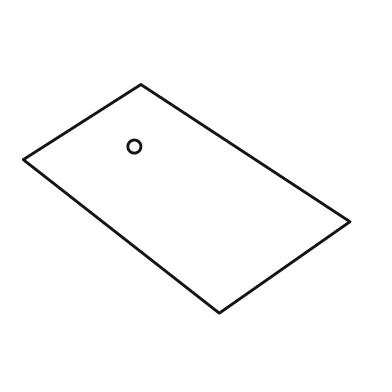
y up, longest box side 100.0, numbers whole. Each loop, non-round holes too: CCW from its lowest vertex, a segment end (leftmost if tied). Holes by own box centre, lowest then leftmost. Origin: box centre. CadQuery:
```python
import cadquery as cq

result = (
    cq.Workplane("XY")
    .moveTo(10.0, -35.0)
    .lineTo(50.0, -7.0)
    .lineTo(-14.0, 35.0)
    .lineTo(-50.0, 12.0)
    .close()
    .moveTo(-16.0, 16.0)
    .circle(2.0)
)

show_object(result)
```